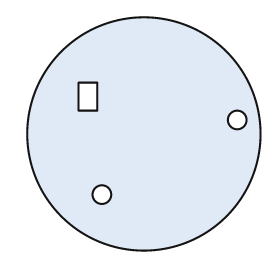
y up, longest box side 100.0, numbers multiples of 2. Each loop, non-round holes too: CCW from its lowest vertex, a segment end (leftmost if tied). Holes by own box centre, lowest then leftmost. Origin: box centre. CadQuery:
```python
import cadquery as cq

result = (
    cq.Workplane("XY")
    .moveTo(0.0, 0.0)
    .circle(50.0)
    .moveTo(-18.0, -26.0)
    .circle(4.0)
    .moveTo(40.0, 6.0)
    .circle(4.0)
    .moveTo(-28.0, 10.0)
    .lineTo(-20.0, 10.0)
    .lineTo(-20.0, 22.0)
    .lineTo(-28.0, 22.0)
    .close()
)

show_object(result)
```